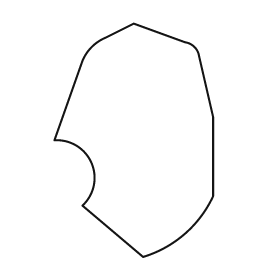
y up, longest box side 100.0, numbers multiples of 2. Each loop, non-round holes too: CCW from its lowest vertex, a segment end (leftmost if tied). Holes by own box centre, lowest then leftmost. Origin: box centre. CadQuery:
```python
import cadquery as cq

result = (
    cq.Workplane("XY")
    .moveTo(4.0, -50.0)
    .threePointArc((22.0, -40.0), (34.0, -24.0))
    .lineTo(34.0, 10.0)
    .lineTo(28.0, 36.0)
    .threePointArc((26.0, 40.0), (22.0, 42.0))
    .lineTo(0.0, 50.0)
    .lineTo(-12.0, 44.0)
    .threePointArc((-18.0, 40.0), (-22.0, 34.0))
    .lineTo(-34.0, 0.0)
    .threePointArc((-18.0, -10.0), (-22.0, -28.0))
    .close()
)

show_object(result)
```